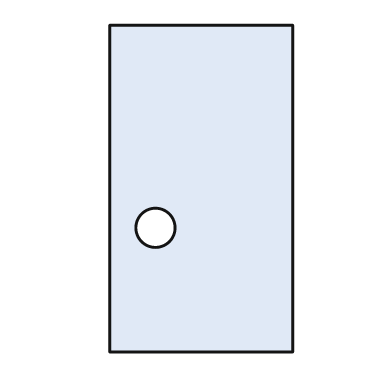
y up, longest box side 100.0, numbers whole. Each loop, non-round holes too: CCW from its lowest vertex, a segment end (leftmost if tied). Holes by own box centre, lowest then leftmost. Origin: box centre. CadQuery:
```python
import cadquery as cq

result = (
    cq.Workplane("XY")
    .moveTo(-28.0, -50.0)
    .lineTo(28.0, -50.0)
    .lineTo(28.0, 50.0)
    .lineTo(-28.0, 50.0)
    .close()
    .moveTo(-14.0, -12.0)
    .circle(6.0)
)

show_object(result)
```